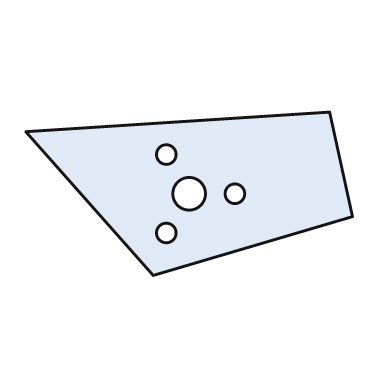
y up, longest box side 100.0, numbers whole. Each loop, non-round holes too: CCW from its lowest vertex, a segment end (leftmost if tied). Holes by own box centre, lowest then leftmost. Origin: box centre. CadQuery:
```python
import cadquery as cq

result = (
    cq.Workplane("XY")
    .moveTo(-11.0, -25.0)
    .lineTo(50.0, -7.0)
    .lineTo(43.0, 25.0)
    .lineTo(-50.0, 19.0)
    .close()
    .moveTo(-7.0, -12.0)
    .circle(3.0)
    .moveTo(0.0, 0.0)
    .circle(5.0)
    .moveTo(14.0, 0.0)
    .circle(3.0)
    .moveTo(-7.0, 12.0)
    .circle(3.0)
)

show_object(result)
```